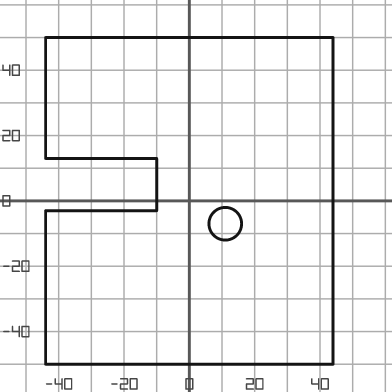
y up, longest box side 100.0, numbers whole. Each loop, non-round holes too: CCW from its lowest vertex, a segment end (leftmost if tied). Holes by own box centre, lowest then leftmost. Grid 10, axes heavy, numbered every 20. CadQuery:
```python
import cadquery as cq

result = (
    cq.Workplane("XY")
    .moveTo(-44.0, -50.0)
    .lineTo(44.0, -50.0)
    .lineTo(44.0, 50.0)
    .lineTo(-44.0, 50.0)
    .lineTo(-44.0, 13.0)
    .lineTo(-10.0, 13.0)
    .lineTo(-10.0, -3.0)
    .lineTo(-44.0, -3.0)
    .close()
    .moveTo(11.0, -7.0)
    .circle(5.0)
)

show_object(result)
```